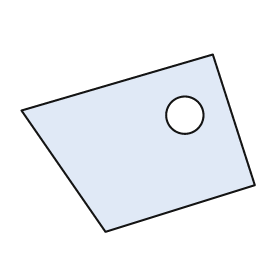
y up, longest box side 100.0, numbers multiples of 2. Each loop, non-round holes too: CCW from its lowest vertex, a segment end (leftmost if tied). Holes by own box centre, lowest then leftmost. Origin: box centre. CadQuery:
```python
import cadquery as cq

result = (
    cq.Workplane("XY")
    .moveTo(-14.0, -38.0)
    .lineTo(50.0, -18.0)
    .lineTo(32.0, 38.0)
    .lineTo(-50.0, 14.0)
    .close()
    .moveTo(20.0, 12.0)
    .circle(8.0)
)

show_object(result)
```